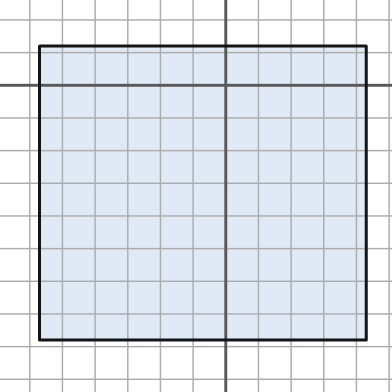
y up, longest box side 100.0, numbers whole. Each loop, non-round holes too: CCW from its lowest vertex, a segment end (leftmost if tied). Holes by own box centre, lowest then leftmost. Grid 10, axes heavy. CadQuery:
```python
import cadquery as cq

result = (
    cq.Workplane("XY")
    .moveTo(-57.0, -78.0)
    .lineTo(43.0, -78.0)
    .lineTo(43.0, 12.0)
    .lineTo(-57.0, 12.0)
    .close()
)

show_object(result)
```